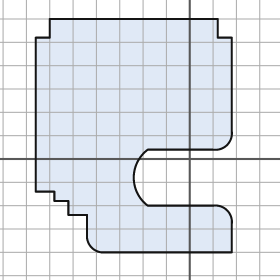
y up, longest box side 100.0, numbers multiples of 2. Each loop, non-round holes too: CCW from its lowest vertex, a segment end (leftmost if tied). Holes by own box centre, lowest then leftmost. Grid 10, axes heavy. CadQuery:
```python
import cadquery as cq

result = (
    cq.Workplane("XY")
    .moveTo(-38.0, -40.0)
    .lineTo(18.0, -40.0)
    .lineTo(18.0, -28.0)
    .threePointArc((16.0, -22.0), (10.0, -20.0))
    .lineTo(-18.0, -20.0)
    .threePointArc((-24.0, -8.0), (-18.0, 4.0))
    .lineTo(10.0, 4.0)
    .threePointArc((16.0, 6.0), (18.0, 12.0))
    .lineTo(18.0, 52.0)
    .lineTo(12.0, 52.0)
    .lineTo(12.0, 60.0)
    .lineTo(-60.0, 60.0)
    .lineTo(-60.0, 52.0)
    .lineTo(-66.0, 52.0)
    .lineTo(-66.0, -14.0)
    .lineTo(-58.0, -14.0)
    .lineTo(-58.0, -18.0)
    .lineTo(-52.0, -18.0)
    .lineTo(-52.0, -24.0)
    .lineTo(-44.0, -24.0)
    .lineTo(-44.0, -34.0)
    .threePointArc((-42.0, -38.0), (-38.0, -40.0))
    .close()
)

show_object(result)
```